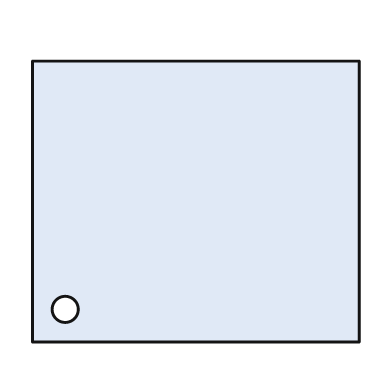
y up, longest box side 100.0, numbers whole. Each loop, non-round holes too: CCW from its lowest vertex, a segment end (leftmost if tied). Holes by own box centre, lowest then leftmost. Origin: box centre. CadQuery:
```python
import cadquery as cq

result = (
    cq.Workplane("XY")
    .moveTo(-50.0, -43.0)
    .lineTo(50.0, -43.0)
    .lineTo(50.0, 43.0)
    .lineTo(-50.0, 43.0)
    .close()
    .moveTo(-40.0, -33.0)
    .circle(4.0)
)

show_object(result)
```